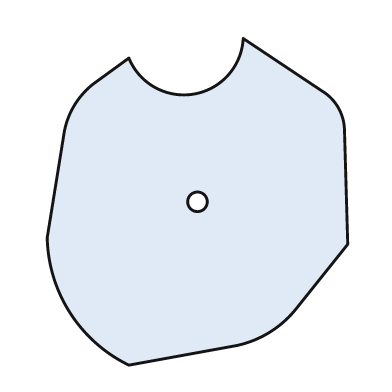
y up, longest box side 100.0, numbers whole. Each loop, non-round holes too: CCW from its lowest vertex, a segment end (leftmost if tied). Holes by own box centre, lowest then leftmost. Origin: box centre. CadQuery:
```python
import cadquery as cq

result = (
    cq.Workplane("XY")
    .moveTo(-21.0, -50.0)
    .lineTo(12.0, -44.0)
    .threePointArc((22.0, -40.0), (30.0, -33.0))
    .lineTo(46.0, -13.0)
    .lineTo(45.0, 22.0)
    .threePointArc((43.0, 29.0), (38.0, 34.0))
    .lineTo(14.0, 50.0)
    .threePointArc((-1.0, 33.0), (-21.0, 44.0))
    .lineTo(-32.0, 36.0)
    .threePointArc((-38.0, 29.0), (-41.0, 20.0))
    .lineTo(-46.0, -11.0)
    .threePointArc((-39.0, -34.0), (-21.0, -50.0))
    .close()
    .moveTo(0.0, 0.0)
    .circle(3.0)
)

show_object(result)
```